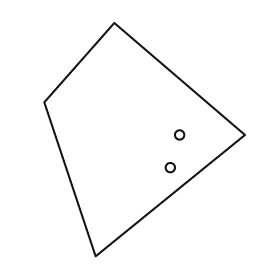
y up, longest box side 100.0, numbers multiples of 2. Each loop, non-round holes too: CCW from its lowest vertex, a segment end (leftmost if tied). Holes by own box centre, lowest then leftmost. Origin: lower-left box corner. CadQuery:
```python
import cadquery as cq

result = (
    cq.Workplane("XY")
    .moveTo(22.0, 0.0)
    .lineTo(86.0, 52.0)
    .lineTo(30.0, 100.0)
    .lineTo(0.0, 66.0)
    .close()
    .moveTo(54.0, 38.0)
    .circle(2.0)
    .moveTo(58.0, 52.0)
    .circle(2.0)
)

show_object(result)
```